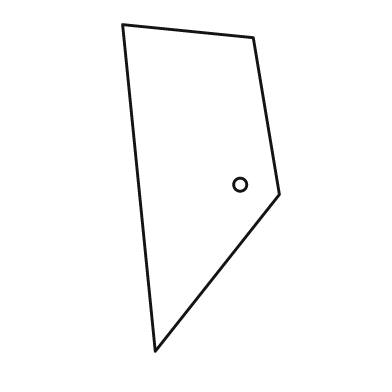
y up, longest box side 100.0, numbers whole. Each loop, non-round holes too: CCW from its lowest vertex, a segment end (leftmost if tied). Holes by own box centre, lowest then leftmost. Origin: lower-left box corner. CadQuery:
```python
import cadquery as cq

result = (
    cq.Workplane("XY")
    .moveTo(10.0, 0.0)
    .lineTo(48.0, 48.0)
    .lineTo(40.0, 96.0)
    .lineTo(0.0, 100.0)
    .close()
    .moveTo(36.0, 51.0)
    .circle(2.0)
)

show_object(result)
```